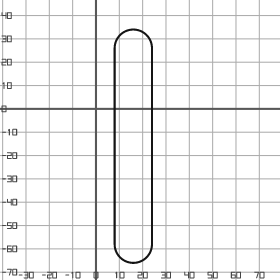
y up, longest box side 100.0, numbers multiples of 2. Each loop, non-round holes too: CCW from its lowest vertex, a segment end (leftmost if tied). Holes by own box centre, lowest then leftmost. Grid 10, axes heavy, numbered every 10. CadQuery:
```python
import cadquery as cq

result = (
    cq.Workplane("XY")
    .moveTo(8.0, -58.0)
    .threePointArc((16.0, -66.0), (24.0, -58.0))
    .lineTo(24.0, 26.0)
    .threePointArc((16.0, 34.0), (8.0, 26.0))
    .close()
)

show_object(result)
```